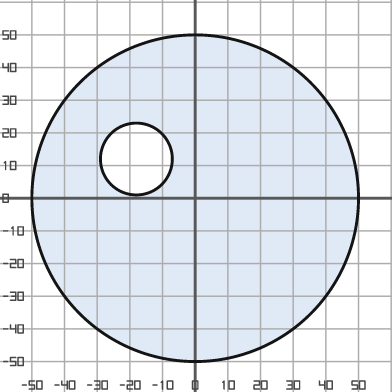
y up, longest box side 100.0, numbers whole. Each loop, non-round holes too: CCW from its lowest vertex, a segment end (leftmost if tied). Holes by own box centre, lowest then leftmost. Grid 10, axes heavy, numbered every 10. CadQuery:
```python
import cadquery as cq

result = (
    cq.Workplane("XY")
    .moveTo(0.0, 0.0)
    .circle(50.0)
    .moveTo(-18.0, 12.0)
    .circle(11.0)
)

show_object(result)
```